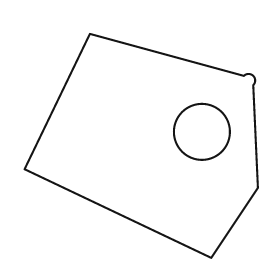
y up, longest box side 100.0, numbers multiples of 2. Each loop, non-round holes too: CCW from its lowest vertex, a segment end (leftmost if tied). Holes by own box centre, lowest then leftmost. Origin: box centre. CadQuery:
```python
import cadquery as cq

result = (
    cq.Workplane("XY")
    .moveTo(30.0, -48.0)
    .lineTo(50.0, -18.0)
    .lineTo(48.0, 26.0)
    .threePointArc((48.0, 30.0), (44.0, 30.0))
    .lineTo(-22.0, 48.0)
    .lineTo(-50.0, -10.0)
    .close()
    .moveTo(26.0, 6.0)
    .circle(12.0)
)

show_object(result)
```